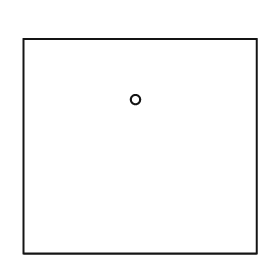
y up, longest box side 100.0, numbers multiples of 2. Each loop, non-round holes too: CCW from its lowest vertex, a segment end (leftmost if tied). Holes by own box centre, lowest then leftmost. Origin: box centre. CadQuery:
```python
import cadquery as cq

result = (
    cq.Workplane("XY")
    .moveTo(-50.0, -46.0)
    .lineTo(50.0, -46.0)
    .lineTo(50.0, 46.0)
    .lineTo(-50.0, 46.0)
    .close()
    .moveTo(-2.0, 20.0)
    .circle(2.0)
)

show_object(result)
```